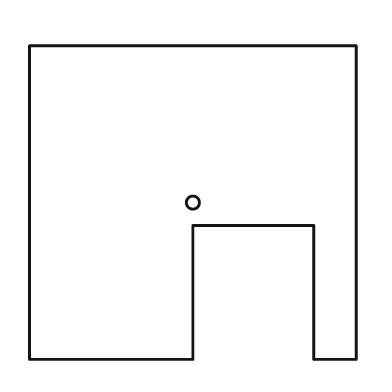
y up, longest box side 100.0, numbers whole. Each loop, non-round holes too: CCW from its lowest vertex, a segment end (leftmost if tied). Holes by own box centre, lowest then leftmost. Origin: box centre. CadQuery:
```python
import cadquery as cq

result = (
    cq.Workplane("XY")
    .moveTo(-50.0, -48.0)
    .lineTo(0.0, -48.0)
    .lineTo(0.0, -7.0)
    .lineTo(37.0, -7.0)
    .lineTo(37.0, -48.0)
    .lineTo(50.0, -48.0)
    .lineTo(50.0, 48.0)
    .lineTo(-50.0, 48.0)
    .close()
    .moveTo(0.0, 0.0)
    .circle(2.0)
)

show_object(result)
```